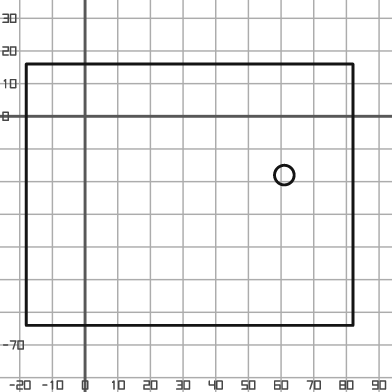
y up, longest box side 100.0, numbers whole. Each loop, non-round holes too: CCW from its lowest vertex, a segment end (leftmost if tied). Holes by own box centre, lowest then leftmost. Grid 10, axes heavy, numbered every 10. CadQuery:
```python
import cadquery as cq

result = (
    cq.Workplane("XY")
    .moveTo(-18.0, -64.0)
    .lineTo(82.0, -64.0)
    .lineTo(82.0, 16.0)
    .lineTo(-18.0, 16.0)
    .close()
    .moveTo(61.0, -18.0)
    .circle(3.0)
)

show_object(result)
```